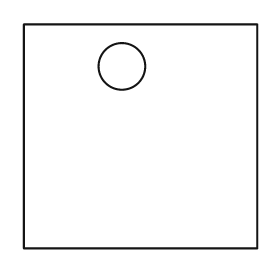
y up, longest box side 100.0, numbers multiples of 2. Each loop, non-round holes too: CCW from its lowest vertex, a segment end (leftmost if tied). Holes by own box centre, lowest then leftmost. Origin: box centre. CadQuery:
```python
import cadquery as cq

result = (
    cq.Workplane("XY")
    .moveTo(-50.0, -48.0)
    .lineTo(50.0, -48.0)
    .lineTo(50.0, 48.0)
    .lineTo(-50.0, 48.0)
    .close()
    .moveTo(-8.0, 30.0)
    .circle(10.0)
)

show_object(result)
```